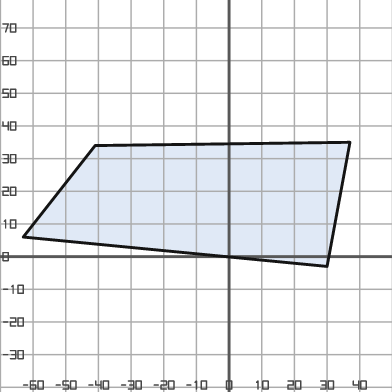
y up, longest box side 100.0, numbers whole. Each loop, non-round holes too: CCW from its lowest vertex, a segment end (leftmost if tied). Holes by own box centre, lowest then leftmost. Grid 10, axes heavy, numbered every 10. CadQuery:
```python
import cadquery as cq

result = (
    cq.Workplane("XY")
    .moveTo(30.0, -3.0)
    .lineTo(37.0, 35.0)
    .lineTo(-41.0, 34.0)
    .lineTo(-63.0, 6.0)
    .close()
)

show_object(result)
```